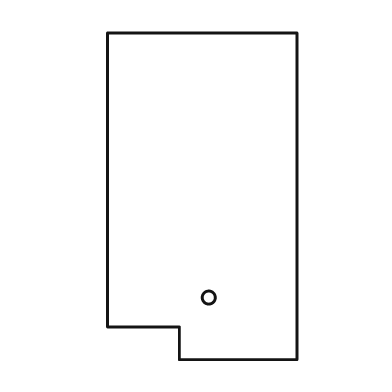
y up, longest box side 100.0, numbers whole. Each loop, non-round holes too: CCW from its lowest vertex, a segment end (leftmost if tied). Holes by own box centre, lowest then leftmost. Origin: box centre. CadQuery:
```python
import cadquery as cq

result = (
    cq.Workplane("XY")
    .moveTo(-7.0, -50.0)
    .lineTo(29.0, -50.0)
    .lineTo(29.0, 50.0)
    .lineTo(-29.0, 50.0)
    .lineTo(-29.0, -40.0)
    .lineTo(-7.0, -40.0)
    .close()
    .moveTo(2.0, -31.0)
    .circle(2.0)
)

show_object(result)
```